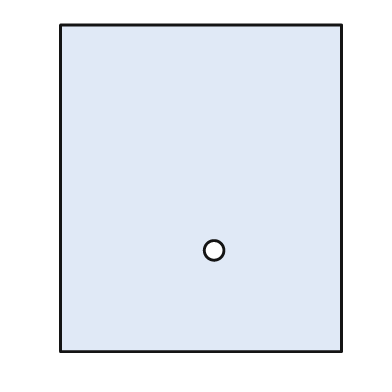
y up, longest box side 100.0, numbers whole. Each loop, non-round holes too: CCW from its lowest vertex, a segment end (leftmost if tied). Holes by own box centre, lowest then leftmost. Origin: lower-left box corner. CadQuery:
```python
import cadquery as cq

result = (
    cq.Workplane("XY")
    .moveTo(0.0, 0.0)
    .lineTo(86.0, 0.0)
    .lineTo(86.0, 100.0)
    .lineTo(0.0, 100.0)
    .close()
    .moveTo(47.0, 31.0)
    .circle(3.0)
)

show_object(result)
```